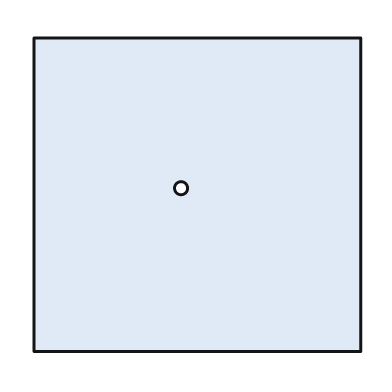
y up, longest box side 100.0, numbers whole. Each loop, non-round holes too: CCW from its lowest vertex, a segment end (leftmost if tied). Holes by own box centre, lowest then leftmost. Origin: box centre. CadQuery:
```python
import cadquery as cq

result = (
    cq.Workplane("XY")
    .moveTo(-50.0, -48.0)
    .lineTo(50.0, -48.0)
    .lineTo(50.0, 48.0)
    .lineTo(-50.0, 48.0)
    .close()
    .moveTo(-5.0, 2.0)
    .circle(2.0)
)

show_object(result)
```